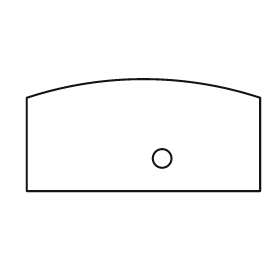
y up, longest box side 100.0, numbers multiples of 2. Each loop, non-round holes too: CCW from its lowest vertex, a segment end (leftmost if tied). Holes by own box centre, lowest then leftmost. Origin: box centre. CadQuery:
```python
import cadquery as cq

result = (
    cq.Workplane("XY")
    .moveTo(-50.0, -24.0)
    .lineTo(50.0, -24.0)
    .lineTo(50.0, 16.0)
    .threePointArc((0.0, 24.0), (-50.0, 16.0))
    .close()
    .moveTo(8.0, -10.0)
    .circle(4.0)
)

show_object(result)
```